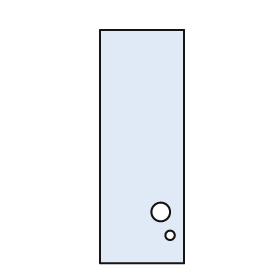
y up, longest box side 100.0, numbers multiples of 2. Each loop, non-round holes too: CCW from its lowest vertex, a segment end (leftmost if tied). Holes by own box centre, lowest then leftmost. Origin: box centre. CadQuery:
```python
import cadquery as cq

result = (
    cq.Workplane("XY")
    .moveTo(-18.0, -50.0)
    .lineTo(18.0, -50.0)
    .lineTo(18.0, 50.0)
    .lineTo(-18.0, 50.0)
    .close()
    .moveTo(12.0, -38.0)
    .circle(2.0)
    .moveTo(8.0, -28.0)
    .circle(4.0)
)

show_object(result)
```